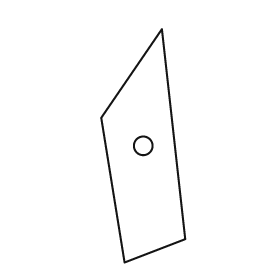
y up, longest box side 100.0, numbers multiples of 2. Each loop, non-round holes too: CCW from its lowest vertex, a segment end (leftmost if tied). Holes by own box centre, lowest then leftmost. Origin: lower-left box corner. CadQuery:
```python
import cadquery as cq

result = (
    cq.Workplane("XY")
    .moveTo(10.0, 0.0)
    .lineTo(36.0, 10.0)
    .lineTo(26.0, 100.0)
    .lineTo(0.0, 62.0)
    .close()
    .moveTo(18.0, 50.0)
    .circle(4.0)
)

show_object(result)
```